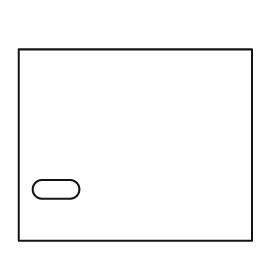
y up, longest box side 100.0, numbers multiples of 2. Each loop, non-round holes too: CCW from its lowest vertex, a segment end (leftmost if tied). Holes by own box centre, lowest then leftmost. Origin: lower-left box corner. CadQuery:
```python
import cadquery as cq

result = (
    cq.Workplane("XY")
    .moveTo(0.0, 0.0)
    .lineTo(100.0, 0.0)
    .lineTo(100.0, 82.0)
    .lineTo(0.0, 82.0)
    .close()
    .moveTo(10.0, 18.0)
    .lineTo(22.0, 18.0)
    .threePointArc((26.0, 22.0), (22.0, 26.0))
    .lineTo(10.0, 26.0)
    .threePointArc((6.0, 22.0), (10.0, 18.0))
    .close()
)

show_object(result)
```